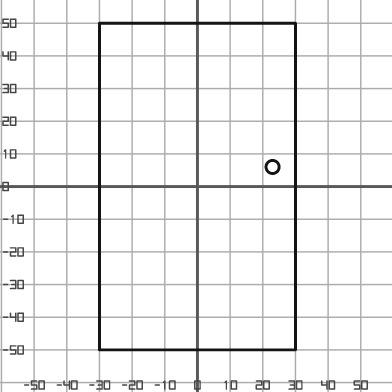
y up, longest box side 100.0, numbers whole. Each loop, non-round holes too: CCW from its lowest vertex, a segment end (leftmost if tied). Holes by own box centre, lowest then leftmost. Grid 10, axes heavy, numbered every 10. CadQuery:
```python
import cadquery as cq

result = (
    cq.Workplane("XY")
    .moveTo(-30.0, -50.0)
    .lineTo(30.0, -50.0)
    .lineTo(30.0, 50.0)
    .lineTo(-30.0, 50.0)
    .close()
    .moveTo(23.0, 6.0)
    .circle(2.0)
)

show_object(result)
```